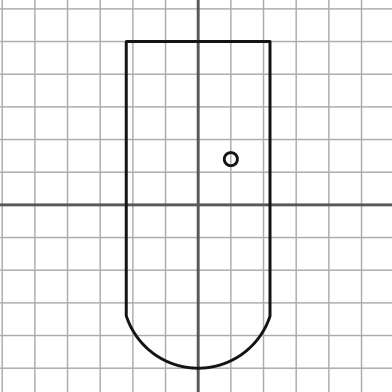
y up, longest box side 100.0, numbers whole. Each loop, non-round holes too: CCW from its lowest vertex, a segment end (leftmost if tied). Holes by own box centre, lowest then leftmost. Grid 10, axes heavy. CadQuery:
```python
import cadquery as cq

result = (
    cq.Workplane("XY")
    .moveTo(-22.0, -34.0)
    .threePointArc((0.0, -50.0), (22.0, -34.0))
    .lineTo(22.0, 50.0)
    .lineTo(-22.0, 50.0)
    .close()
    .moveTo(10.0, 14.0)
    .circle(2.0)
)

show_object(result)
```